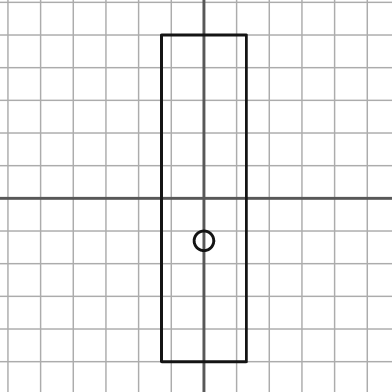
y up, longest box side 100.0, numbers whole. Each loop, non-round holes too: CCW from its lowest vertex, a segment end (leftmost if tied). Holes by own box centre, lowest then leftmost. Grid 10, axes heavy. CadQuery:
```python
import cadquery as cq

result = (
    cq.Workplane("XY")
    .moveTo(-13.0, -50.0)
    .lineTo(13.0, -50.0)
    .lineTo(13.0, 50.0)
    .lineTo(-13.0, 50.0)
    .close()
    .moveTo(0.0, -13.0)
    .circle(3.0)
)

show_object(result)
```